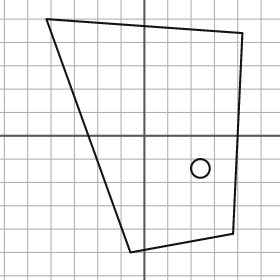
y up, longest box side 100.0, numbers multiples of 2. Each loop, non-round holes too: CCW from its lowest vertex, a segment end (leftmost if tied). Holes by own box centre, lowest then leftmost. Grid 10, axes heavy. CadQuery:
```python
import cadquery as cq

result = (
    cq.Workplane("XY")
    .moveTo(-6.0, -50.0)
    .lineTo(38.0, -42.0)
    .lineTo(42.0, 44.0)
    .lineTo(-42.0, 50.0)
    .close()
    .moveTo(24.0, -14.0)
    .circle(4.0)
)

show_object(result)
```